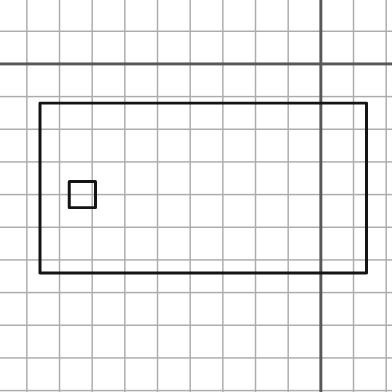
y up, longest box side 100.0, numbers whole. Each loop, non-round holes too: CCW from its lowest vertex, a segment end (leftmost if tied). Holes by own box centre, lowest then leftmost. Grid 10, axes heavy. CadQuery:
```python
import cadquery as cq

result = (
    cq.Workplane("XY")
    .moveTo(-86.0, -64.0)
    .lineTo(14.0, -64.0)
    .lineTo(14.0, -12.0)
    .lineTo(-86.0, -12.0)
    .close()
    .moveTo(-77.0, -44.0)
    .lineTo(-69.0, -44.0)
    .lineTo(-69.0, -36.0)
    .lineTo(-77.0, -36.0)
    .close()
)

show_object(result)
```